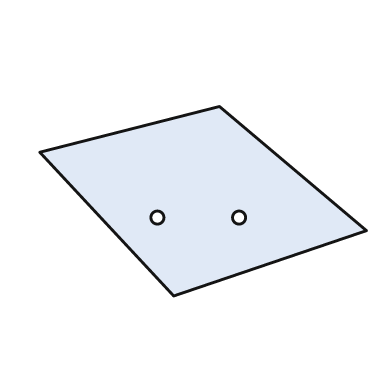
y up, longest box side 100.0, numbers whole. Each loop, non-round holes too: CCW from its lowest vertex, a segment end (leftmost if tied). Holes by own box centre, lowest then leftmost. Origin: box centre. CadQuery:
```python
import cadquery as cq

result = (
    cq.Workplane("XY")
    .moveTo(-9.0, -29.0)
    .lineTo(50.0, -9.0)
    .lineTo(5.0, 29.0)
    .lineTo(-50.0, 15.0)
    .close()
    .moveTo(-14.0, -5.0)
    .circle(2.0)
    .moveTo(11.0, -5.0)
    .circle(2.0)
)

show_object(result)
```